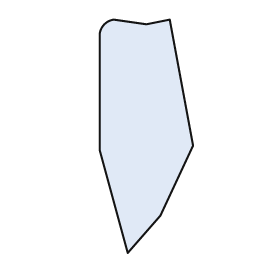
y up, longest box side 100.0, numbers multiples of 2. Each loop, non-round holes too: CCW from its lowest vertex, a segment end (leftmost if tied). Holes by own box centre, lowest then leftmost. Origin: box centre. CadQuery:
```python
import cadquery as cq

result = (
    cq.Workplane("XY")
    .moveTo(-8.0, -50.0)
    .lineTo(6.0, -34.0)
    .lineTo(20.0, -4.0)
    .lineTo(10.0, 50.0)
    .lineTo(0.0, 48.0)
    .lineTo(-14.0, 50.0)
    .threePointArc((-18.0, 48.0), (-20.0, 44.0))
    .lineTo(-20.0, -6.0)
    .close()
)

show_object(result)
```